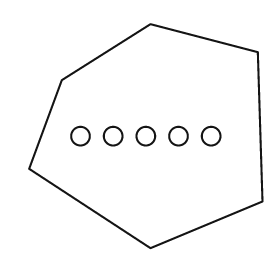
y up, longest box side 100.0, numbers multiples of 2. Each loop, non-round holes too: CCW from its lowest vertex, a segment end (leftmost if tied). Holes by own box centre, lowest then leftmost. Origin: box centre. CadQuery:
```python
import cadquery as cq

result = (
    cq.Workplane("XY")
    .moveTo(2.0, -48.0)
    .lineTo(50.0, -28.0)
    .lineTo(48.0, 36.0)
    .lineTo(2.0, 48.0)
    .lineTo(-36.0, 24.0)
    .lineTo(-50.0, -14.0)
    .close()
    .moveTo(-28.0, 0.0)
    .circle(4.0)
    .moveTo(-14.0, 0.0)
    .circle(4.0)
    .moveTo(0.0, 0.0)
    .circle(4.0)
    .moveTo(14.0, 0.0)
    .circle(4.0)
    .moveTo(28.0, 0.0)
    .circle(4.0)
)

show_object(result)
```